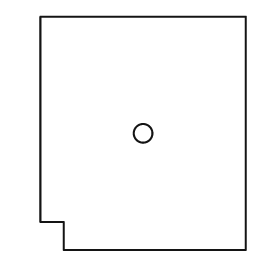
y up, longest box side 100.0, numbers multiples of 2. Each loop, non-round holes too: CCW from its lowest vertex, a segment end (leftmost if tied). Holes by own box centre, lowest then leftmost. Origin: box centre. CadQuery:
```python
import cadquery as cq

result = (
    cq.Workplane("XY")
    .moveTo(-34.0, -50.0)
    .lineTo(44.0, -50.0)
    .lineTo(44.0, 50.0)
    .lineTo(-44.0, 50.0)
    .lineTo(-44.0, -38.0)
    .lineTo(-34.0, -38.0)
    .close()
    .moveTo(0.0, 0.0)
    .circle(4.0)
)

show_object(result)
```